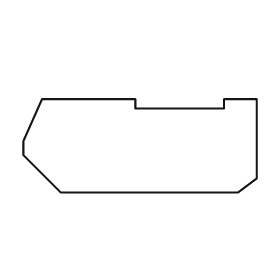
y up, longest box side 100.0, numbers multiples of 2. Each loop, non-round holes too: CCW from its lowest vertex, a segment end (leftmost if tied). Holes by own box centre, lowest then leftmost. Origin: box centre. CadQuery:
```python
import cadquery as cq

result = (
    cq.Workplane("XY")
    .moveTo(-34.0, -20.0)
    .lineTo(42.0, -20.0)
    .lineTo(50.0, -14.0)
    .lineTo(50.0, 20.0)
    .lineTo(36.0, 20.0)
    .lineTo(36.0, 16.0)
    .lineTo(-2.0, 16.0)
    .lineTo(-2.0, 20.0)
    .lineTo(-42.0, 20.0)
    .lineTo(-50.0, 2.0)
    .lineTo(-50.0, -4.0)
    .close()
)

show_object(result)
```